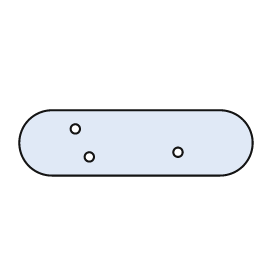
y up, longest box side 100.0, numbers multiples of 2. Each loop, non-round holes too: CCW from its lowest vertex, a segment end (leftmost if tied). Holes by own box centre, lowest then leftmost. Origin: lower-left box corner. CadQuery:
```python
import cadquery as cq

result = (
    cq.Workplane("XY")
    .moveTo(14.0, 0.0)
    .lineTo(86.0, 0.0)
    .threePointArc((100.0, 14.0), (86.0, 28.0))
    .lineTo(14.0, 28.0)
    .threePointArc((0.0, 14.0), (14.0, 0.0))
    .close()
    .moveTo(30.0, 8.0)
    .circle(2.0)
    .moveTo(68.0, 10.0)
    .circle(2.0)
    .moveTo(24.0, 20.0)
    .circle(2.0)
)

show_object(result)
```